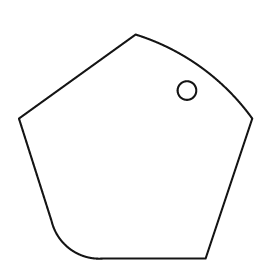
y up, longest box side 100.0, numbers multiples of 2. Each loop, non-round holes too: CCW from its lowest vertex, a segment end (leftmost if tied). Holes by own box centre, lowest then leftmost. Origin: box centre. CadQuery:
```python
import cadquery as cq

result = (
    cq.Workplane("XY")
    .moveTo(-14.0, -48.0)
    .lineTo(30.0, -48.0)
    .lineTo(50.0, 12.0)
    .threePointArc((28.0, 34.0), (0.0, 48.0))
    .lineTo(-50.0, 12.0)
    .lineTo(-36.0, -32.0)
    .threePointArc((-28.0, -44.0), (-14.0, -48.0))
    .close()
    .moveTo(22.0, 24.0)
    .circle(4.0)
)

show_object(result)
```